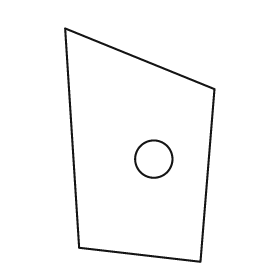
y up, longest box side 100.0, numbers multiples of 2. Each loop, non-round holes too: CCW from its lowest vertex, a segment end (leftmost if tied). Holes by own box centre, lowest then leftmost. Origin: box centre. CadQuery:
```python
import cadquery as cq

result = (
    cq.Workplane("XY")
    .moveTo(26.0, -50.0)
    .lineTo(32.0, 24.0)
    .lineTo(-32.0, 50.0)
    .lineTo(-26.0, -44.0)
    .close()
    .moveTo(6.0, -6.0)
    .circle(8.0)
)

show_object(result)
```